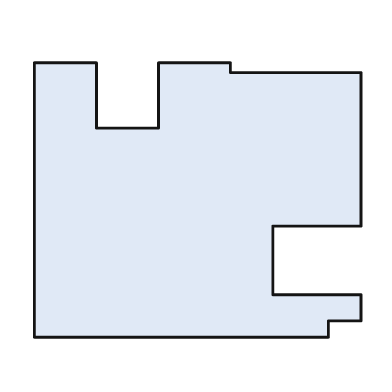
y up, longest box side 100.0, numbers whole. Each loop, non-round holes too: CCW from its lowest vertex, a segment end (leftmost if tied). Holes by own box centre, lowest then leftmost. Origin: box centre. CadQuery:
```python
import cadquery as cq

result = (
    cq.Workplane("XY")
    .moveTo(-50.0, -42.0)
    .lineTo(40.0, -42.0)
    .lineTo(40.0, -37.0)
    .lineTo(50.0, -37.0)
    .lineTo(50.0, -29.0)
    .lineTo(23.0, -29.0)
    .lineTo(23.0, -8.0)
    .lineTo(50.0, -8.0)
    .lineTo(50.0, 39.0)
    .lineTo(10.0, 39.0)
    .lineTo(10.0, 42.0)
    .lineTo(-12.0, 42.0)
    .lineTo(-12.0, 22.0)
    .lineTo(-31.0, 22.0)
    .lineTo(-31.0, 42.0)
    .lineTo(-50.0, 42.0)
    .close()
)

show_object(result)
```